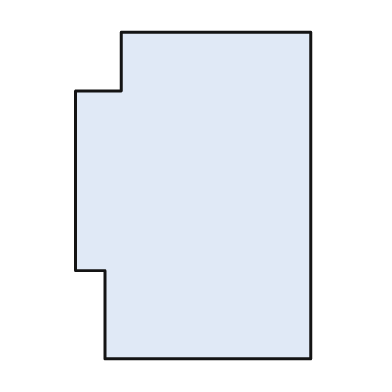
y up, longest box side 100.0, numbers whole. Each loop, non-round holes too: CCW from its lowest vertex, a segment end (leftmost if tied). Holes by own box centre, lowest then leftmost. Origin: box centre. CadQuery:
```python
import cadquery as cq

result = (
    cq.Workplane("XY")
    .moveTo(-27.0, -50.0)
    .lineTo(36.0, -50.0)
    .lineTo(36.0, 50.0)
    .lineTo(-22.0, 50.0)
    .lineTo(-22.0, 32.0)
    .lineTo(-36.0, 32.0)
    .lineTo(-36.0, -23.0)
    .lineTo(-27.0, -23.0)
    .close()
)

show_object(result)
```